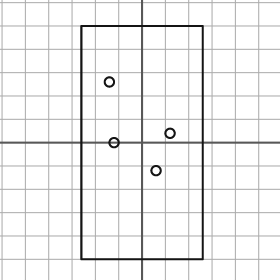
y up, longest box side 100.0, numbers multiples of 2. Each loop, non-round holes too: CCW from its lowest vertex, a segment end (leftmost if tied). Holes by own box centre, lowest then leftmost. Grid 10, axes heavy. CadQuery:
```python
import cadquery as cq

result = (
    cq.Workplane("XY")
    .moveTo(-26.0, -50.0)
    .lineTo(26.0, -50.0)
    .lineTo(26.0, 50.0)
    .lineTo(-26.0, 50.0)
    .close()
    .moveTo(6.0, -12.0)
    .circle(2.0)
    .moveTo(-12.0, 0.0)
    .circle(2.0)
    .moveTo(12.0, 4.0)
    .circle(2.0)
    .moveTo(-14.0, 26.0)
    .circle(2.0)
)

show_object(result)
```